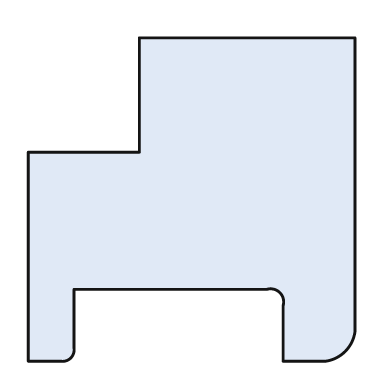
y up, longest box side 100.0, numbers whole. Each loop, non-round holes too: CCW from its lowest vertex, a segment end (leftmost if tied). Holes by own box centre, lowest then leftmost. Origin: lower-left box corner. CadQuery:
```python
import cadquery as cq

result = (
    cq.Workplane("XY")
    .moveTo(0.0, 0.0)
    .lineTo(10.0, 0.0)
    .threePointArc((13.0, 1.0), (14.0, 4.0))
    .lineTo(14.0, 22.0)
    .lineTo(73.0, 22.0)
    .threePointArc((77.0, 21.0), (78.0, 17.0))
    .lineTo(78.0, 0.0)
    .lineTo(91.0, 0.0)
    .threePointArc((97.0, 3.0), (100.0, 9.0))
    .lineTo(100.0, 99.0)
    .lineTo(34.0, 99.0)
    .lineTo(34.0, 64.0)
    .lineTo(0.0, 64.0)
    .close()
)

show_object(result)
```